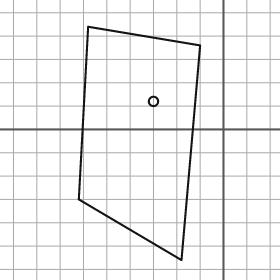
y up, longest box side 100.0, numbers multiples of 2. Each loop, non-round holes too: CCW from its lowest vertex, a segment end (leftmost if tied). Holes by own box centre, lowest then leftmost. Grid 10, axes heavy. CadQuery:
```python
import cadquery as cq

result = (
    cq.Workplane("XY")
    .moveTo(-18.0, -56.0)
    .lineTo(-10.0, 36.0)
    .lineTo(-58.0, 44.0)
    .lineTo(-62.0, -30.0)
    .close()
    .moveTo(-30.0, 12.0)
    .circle(2.0)
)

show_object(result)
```